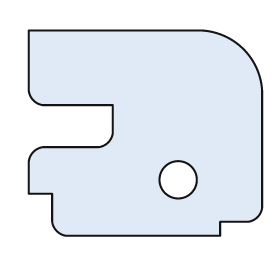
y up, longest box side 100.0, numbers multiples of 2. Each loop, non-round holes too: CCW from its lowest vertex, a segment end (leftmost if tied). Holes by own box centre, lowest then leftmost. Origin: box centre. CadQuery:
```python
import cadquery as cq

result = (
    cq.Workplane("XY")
    .moveTo(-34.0, -44.0)
    .lineTo(32.0, -44.0)
    .lineTo(32.0, -38.0)
    .lineTo(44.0, -38.0)
    .threePointArc((48.0, -36.0), (50.0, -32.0))
    .lineTo(50.0, 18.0)
    .threePointArc((42.0, 36.0), (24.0, 44.0))
    .lineTo(-50.0, 44.0)
    .lineTo(-50.0, 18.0)
    .threePointArc((-48.0, 14.0), (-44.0, 12.0))
    .lineTo(-14.0, 12.0)
    .lineTo(-14.0, 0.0)
    .threePointArc((-16.0, -4.0), (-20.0, -6.0))
    .lineTo(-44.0, -6.0)
    .threePointArc((-48.0, -8.0), (-50.0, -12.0))
    .lineTo(-50.0, -26.0)
    .lineTo(-40.0, -26.0)
    .lineTo(-40.0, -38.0)
    .threePointArc((-38.0, -42.0), (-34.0, -44.0))
    .close()
    .moveTo(14.0, -20.0)
    .circle(8.0)
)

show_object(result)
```